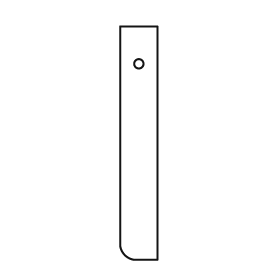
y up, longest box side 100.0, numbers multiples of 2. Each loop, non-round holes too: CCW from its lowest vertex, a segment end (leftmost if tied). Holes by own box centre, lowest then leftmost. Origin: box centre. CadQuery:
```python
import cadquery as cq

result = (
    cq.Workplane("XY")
    .moveTo(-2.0, -50.0)
    .lineTo(8.0, -50.0)
    .lineTo(8.0, 50.0)
    .lineTo(-8.0, 50.0)
    .lineTo(-8.0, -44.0)
    .threePointArc((-6.0, -48.0), (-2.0, -50.0))
    .close()
    .moveTo(0.0, 34.0)
    .circle(2.0)
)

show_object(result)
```